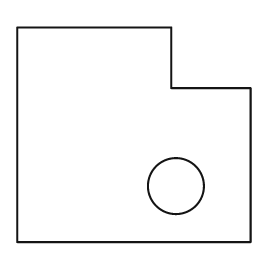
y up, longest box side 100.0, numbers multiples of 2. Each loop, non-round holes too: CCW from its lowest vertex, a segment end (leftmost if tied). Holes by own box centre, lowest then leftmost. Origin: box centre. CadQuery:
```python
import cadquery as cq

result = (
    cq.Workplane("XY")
    .moveTo(-50.0, -46.0)
    .lineTo(50.0, -46.0)
    .lineTo(50.0, 20.0)
    .lineTo(16.0, 20.0)
    .lineTo(16.0, 46.0)
    .lineTo(-50.0, 46.0)
    .close()
    .moveTo(18.0, -22.0)
    .circle(12.0)
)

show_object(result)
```